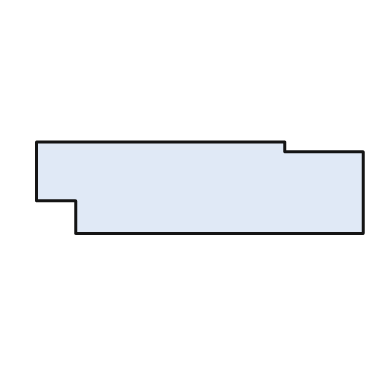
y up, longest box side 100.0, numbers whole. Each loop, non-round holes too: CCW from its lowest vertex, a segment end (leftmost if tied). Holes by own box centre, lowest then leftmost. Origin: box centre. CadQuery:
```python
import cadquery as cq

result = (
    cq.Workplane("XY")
    .moveTo(-38.0, -14.0)
    .lineTo(50.0, -14.0)
    .lineTo(50.0, 11.0)
    .lineTo(26.0, 11.0)
    .lineTo(26.0, 14.0)
    .lineTo(-50.0, 14.0)
    .lineTo(-50.0, -4.0)
    .lineTo(-38.0, -4.0)
    .close()
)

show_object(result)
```